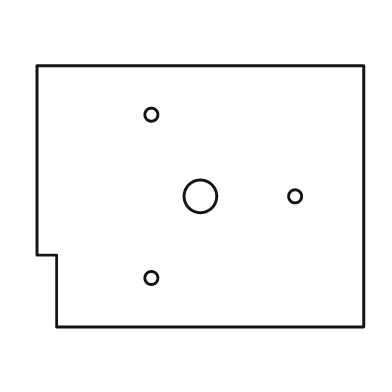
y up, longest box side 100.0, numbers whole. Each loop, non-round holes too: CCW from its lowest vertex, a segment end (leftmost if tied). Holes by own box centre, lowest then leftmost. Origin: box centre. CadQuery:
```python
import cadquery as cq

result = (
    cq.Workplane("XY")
    .moveTo(-44.0, -40.0)
    .lineTo(50.0, -40.0)
    .lineTo(50.0, 40.0)
    .lineTo(-50.0, 40.0)
    .lineTo(-50.0, -18.0)
    .lineTo(-44.0, -18.0)
    .close()
    .moveTo(-15.0, -25.0)
    .circle(2.0)
    .moveTo(0.0, 0.0)
    .circle(5.0)
    .moveTo(29.0, 0.0)
    .circle(2.0)
    .moveTo(-15.0, 25.0)
    .circle(2.0)
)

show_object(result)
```